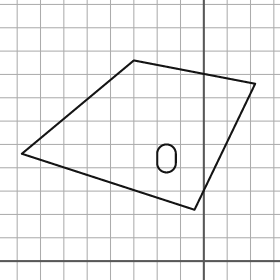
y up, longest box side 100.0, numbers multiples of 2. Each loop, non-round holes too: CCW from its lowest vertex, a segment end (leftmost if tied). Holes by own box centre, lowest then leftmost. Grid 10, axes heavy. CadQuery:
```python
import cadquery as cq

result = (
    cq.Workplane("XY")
    .moveTo(-4.0, 22.0)
    .lineTo(22.0, 76.0)
    .lineTo(-30.0, 86.0)
    .lineTo(-78.0, 46.0)
    .close()
    .moveTo(-20.0, 42.0)
    .threePointArc((-16.0, 38.0), (-12.0, 42.0))
    .lineTo(-12.0, 46.0)
    .threePointArc((-16.0, 50.0), (-20.0, 46.0))
    .close()
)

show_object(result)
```